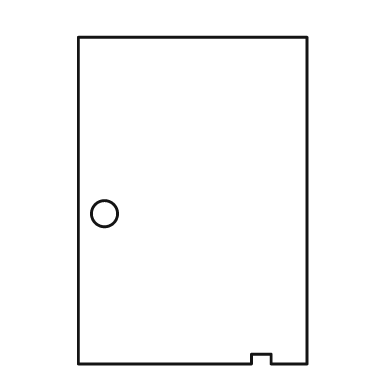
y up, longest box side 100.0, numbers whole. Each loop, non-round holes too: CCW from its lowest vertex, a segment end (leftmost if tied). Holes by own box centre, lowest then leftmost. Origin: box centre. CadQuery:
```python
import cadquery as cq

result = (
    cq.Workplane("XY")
    .moveTo(-35.0, -50.0)
    .lineTo(18.0, -50.0)
    .lineTo(18.0, -47.0)
    .lineTo(24.0, -47.0)
    .lineTo(24.0, -50.0)
    .lineTo(35.0, -50.0)
    .lineTo(35.0, 50.0)
    .lineTo(-35.0, 50.0)
    .close()
    .moveTo(-27.0, -4.0)
    .circle(4.0)
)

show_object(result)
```